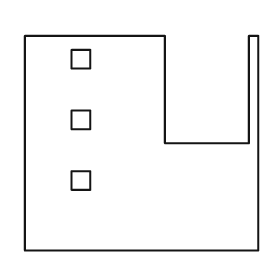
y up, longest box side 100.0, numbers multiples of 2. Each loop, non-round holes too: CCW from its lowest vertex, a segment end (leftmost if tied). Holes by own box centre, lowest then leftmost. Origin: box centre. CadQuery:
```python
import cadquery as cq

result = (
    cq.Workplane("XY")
    .moveTo(-50.0, -46.0)
    .lineTo(50.0, -46.0)
    .lineTo(50.0, 46.0)
    .lineTo(46.0, 46.0)
    .lineTo(46.0, 0.0)
    .lineTo(10.0, 0.0)
    .lineTo(10.0, 46.0)
    .lineTo(-50.0, 46.0)
    .close()
    .moveTo(-30.0, -20.0)
    .lineTo(-22.0, -20.0)
    .lineTo(-22.0, -12.0)
    .lineTo(-30.0, -12.0)
    .close()
    .moveTo(-30.0, 6.0)
    .lineTo(-22.0, 6.0)
    .lineTo(-22.0, 14.0)
    .lineTo(-30.0, 14.0)
    .close()
    .moveTo(-30.0, 32.0)
    .lineTo(-22.0, 32.0)
    .lineTo(-22.0, 40.0)
    .lineTo(-30.0, 40.0)
    .close()
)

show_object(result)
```